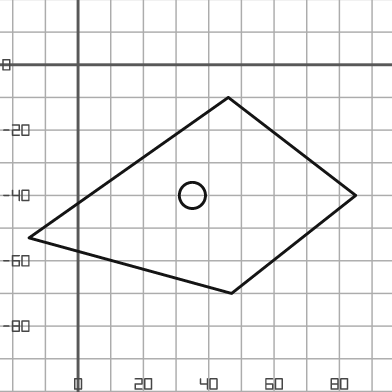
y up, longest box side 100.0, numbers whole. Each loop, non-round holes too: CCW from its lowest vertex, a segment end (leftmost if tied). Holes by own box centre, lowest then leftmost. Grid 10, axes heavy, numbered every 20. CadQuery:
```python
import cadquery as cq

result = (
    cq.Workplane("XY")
    .moveTo(47.0, -70.0)
    .lineTo(85.0, -40.0)
    .lineTo(46.0, -10.0)
    .lineTo(-15.0, -53.0)
    .close()
    .moveTo(35.0, -40.0)
    .circle(4.0)
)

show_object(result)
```